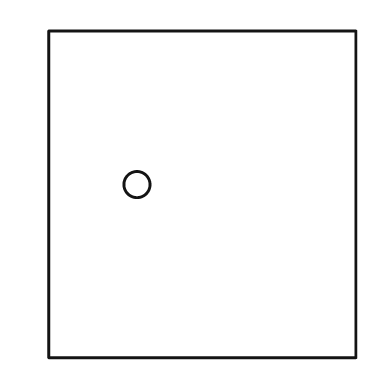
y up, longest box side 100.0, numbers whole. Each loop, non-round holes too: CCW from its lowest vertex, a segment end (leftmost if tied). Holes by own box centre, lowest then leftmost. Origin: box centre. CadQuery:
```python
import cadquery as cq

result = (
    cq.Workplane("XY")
    .moveTo(-47.0, -50.0)
    .lineTo(47.0, -50.0)
    .lineTo(47.0, 50.0)
    .lineTo(-47.0, 50.0)
    .close()
    .moveTo(-20.0, 3.0)
    .circle(4.0)
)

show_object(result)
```